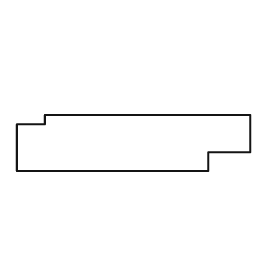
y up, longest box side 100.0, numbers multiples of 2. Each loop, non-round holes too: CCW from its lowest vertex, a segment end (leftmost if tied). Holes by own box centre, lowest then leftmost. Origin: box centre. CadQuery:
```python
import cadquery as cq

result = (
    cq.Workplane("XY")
    .moveTo(-50.0, -12.0)
    .lineTo(32.0, -12.0)
    .lineTo(32.0, -4.0)
    .lineTo(50.0, -4.0)
    .lineTo(50.0, 12.0)
    .lineTo(-38.0, 12.0)
    .lineTo(-38.0, 8.0)
    .lineTo(-50.0, 8.0)
    .close()
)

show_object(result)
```